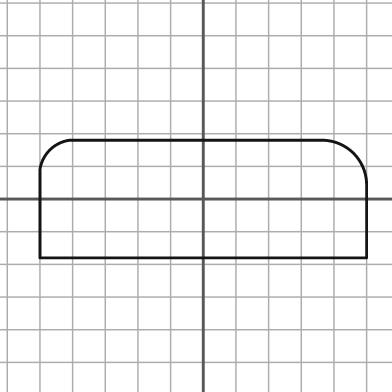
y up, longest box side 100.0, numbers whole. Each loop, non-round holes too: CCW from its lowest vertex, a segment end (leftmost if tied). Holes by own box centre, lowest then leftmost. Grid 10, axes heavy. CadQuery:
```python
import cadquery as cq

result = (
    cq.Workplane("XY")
    .moveTo(-50.0, -18.0)
    .lineTo(50.0, -18.0)
    .lineTo(50.0, 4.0)
    .threePointArc((46.0, 14.0), (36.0, 18.0))
    .lineTo(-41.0, 18.0)
    .threePointArc((-47.0, 15.0), (-50.0, 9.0))
    .close()
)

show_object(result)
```